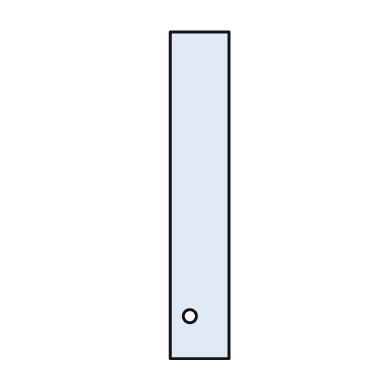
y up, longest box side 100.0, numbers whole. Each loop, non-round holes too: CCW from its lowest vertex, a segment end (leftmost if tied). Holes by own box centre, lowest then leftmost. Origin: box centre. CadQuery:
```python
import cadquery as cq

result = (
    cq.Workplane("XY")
    .moveTo(-9.0, -50.0)
    .lineTo(9.0, -50.0)
    .lineTo(9.0, 50.0)
    .lineTo(-9.0, 50.0)
    .close()
    .moveTo(-3.0, -37.0)
    .circle(2.0)
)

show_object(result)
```